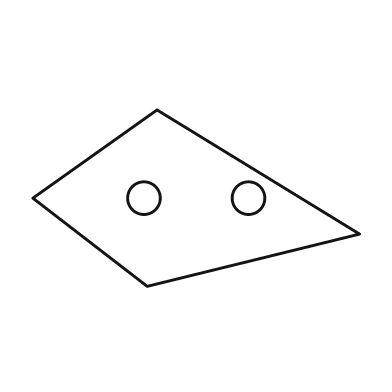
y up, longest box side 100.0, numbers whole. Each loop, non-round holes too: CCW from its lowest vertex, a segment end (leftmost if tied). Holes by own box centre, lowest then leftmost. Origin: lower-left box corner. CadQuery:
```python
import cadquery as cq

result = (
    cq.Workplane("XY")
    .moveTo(35.0, 0.0)
    .lineTo(100.0, 16.0)
    .lineTo(38.0, 54.0)
    .lineTo(0.0, 27.0)
    .close()
    .moveTo(34.0, 27.0)
    .circle(5.0)
    .moveTo(66.0, 27.0)
    .circle(5.0)
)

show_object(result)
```